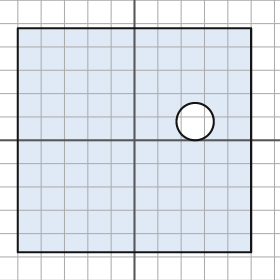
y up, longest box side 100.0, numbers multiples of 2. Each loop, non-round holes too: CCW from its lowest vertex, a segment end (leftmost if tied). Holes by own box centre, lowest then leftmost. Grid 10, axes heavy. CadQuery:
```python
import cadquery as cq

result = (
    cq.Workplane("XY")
    .moveTo(-50.0, -48.0)
    .lineTo(50.0, -48.0)
    .lineTo(50.0, 48.0)
    .lineTo(-50.0, 48.0)
    .close()
    .moveTo(26.0, 8.0)
    .circle(8.0)
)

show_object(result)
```